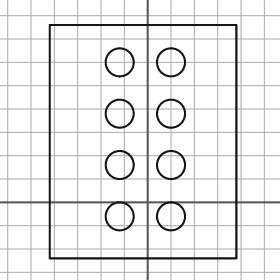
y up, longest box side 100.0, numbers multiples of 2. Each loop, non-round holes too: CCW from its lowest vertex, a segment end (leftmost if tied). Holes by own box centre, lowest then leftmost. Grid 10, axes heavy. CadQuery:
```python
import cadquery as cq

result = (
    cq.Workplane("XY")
    .moveTo(-42.0, -24.0)
    .lineTo(38.0, -24.0)
    .lineTo(38.0, 76.0)
    .lineTo(-42.0, 76.0)
    .close()
    .moveTo(-12.0, -6.0)
    .circle(6.0)
    .moveTo(10.0, -6.0)
    .circle(6.0)
    .moveTo(-12.0, 16.0)
    .circle(6.0)
    .moveTo(10.0, 16.0)
    .circle(6.0)
    .moveTo(-12.0, 38.0)
    .circle(6.0)
    .moveTo(10.0, 38.0)
    .circle(6.0)
    .moveTo(-12.0, 60.0)
    .circle(6.0)
    .moveTo(10.0, 60.0)
    .circle(6.0)
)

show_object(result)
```